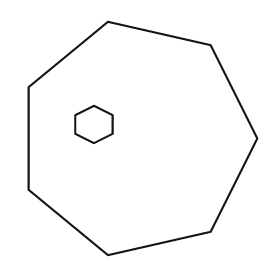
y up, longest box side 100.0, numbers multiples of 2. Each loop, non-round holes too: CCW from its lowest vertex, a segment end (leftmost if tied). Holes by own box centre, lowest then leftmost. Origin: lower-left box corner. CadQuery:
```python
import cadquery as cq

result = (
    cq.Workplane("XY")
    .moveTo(34.0, 0.0)
    .lineTo(78.0, 10.0)
    .lineTo(98.0, 50.0)
    .lineTo(78.0, 90.0)
    .lineTo(34.0, 100.0)
    .lineTo(0.0, 72.0)
    .lineTo(0.0, 28.0)
    .close()
    .moveTo(28.0, 48.0)
    .lineTo(36.0, 52.0)
    .lineTo(36.0, 60.0)
    .lineTo(28.0, 64.0)
    .lineTo(20.0, 60.0)
    .lineTo(20.0, 52.0)
    .close()
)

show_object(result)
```